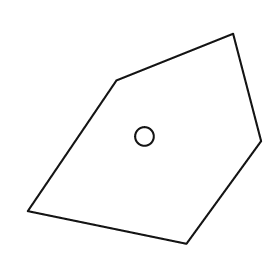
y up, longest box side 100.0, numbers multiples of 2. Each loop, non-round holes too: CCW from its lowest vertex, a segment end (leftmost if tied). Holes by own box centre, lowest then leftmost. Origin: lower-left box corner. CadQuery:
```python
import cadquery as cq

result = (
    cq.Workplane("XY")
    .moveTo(68.0, 0.0)
    .lineTo(100.0, 44.0)
    .lineTo(88.0, 90.0)
    .lineTo(38.0, 70.0)
    .lineTo(0.0, 14.0)
    .close()
    .moveTo(50.0, 46.0)
    .circle(4.0)
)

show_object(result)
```